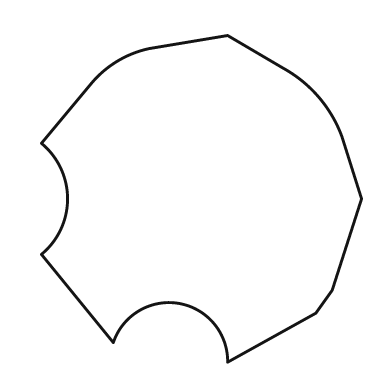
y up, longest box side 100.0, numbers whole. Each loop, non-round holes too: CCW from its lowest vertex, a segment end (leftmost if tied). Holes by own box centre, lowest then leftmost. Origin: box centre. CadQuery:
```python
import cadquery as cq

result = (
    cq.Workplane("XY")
    .moveTo(8.0, -50.0)
    .lineTo(35.0, -35.0)
    .lineTo(40.0, -28.0)
    .lineTo(49.0, 0.0)
    .lineTo(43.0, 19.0)
    .threePointArc((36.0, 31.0), (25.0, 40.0))
    .lineTo(8.0, 50.0)
    .lineTo(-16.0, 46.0)
    .threePointArc((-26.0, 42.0), (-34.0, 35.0))
    .lineTo(-49.0, 17.0)
    .threePointArc((-41.0, 0.0), (-49.0, -17.0))
    .lineTo(-27.0, -44.0)
    .threePointArc((-7.0, -32.0), (8.0, -50.0))
    .close()
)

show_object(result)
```